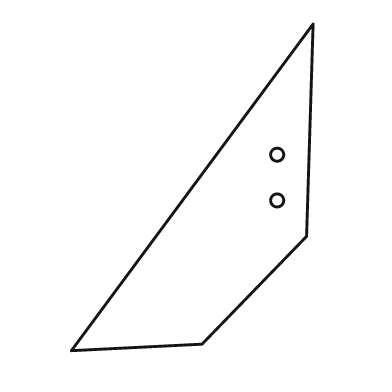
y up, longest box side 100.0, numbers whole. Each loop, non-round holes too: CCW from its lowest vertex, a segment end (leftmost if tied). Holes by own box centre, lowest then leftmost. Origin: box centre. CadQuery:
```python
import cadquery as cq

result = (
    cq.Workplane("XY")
    .moveTo(-37.0, -50.0)
    .lineTo(3.0, -48.0)
    .lineTo(35.0, -15.0)
    .lineTo(37.0, 50.0)
    .close()
    .moveTo(26.0, -4.0)
    .circle(2.0)
    .moveTo(26.0, 10.0)
    .circle(2.0)
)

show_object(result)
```